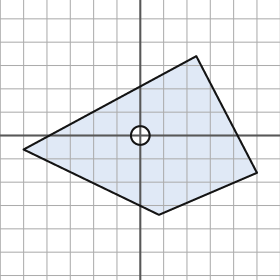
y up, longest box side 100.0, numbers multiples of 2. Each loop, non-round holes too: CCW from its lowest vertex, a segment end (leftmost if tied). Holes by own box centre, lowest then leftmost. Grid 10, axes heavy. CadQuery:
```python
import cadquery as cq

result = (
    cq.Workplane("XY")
    .moveTo(8.0, -34.0)
    .lineTo(50.0, -16.0)
    .lineTo(24.0, 34.0)
    .lineTo(-50.0, -6.0)
    .close()
    .moveTo(0.0, 0.0)
    .circle(4.0)
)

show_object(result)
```